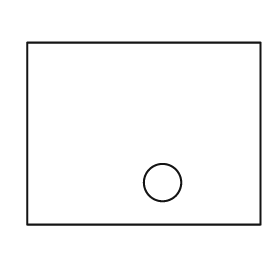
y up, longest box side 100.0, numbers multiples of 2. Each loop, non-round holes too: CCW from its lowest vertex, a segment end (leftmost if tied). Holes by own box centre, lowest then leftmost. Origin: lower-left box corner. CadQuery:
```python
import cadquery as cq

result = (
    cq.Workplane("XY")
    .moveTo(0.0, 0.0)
    .lineTo(100.0, 0.0)
    .lineTo(100.0, 78.0)
    .lineTo(0.0, 78.0)
    .close()
    .moveTo(58.0, 18.0)
    .circle(8.0)
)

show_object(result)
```